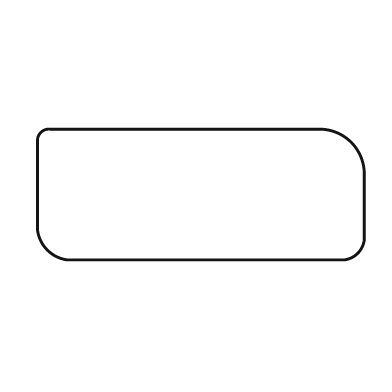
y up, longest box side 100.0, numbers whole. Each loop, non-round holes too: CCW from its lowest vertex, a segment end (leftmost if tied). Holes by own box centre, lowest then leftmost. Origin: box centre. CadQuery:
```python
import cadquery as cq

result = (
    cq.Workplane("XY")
    .moveTo(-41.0, -20.0)
    .lineTo(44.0, -20.0)
    .threePointArc((48.0, -18.0), (50.0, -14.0))
    .lineTo(50.0, 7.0)
    .threePointArc((46.0, 16.0), (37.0, 20.0))
    .lineTo(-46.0, 20.0)
    .threePointArc((-49.0, 19.0), (-50.0, 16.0))
    .lineTo(-50.0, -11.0)
    .threePointArc((-47.0, -17.0), (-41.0, -20.0))
    .close()
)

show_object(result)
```